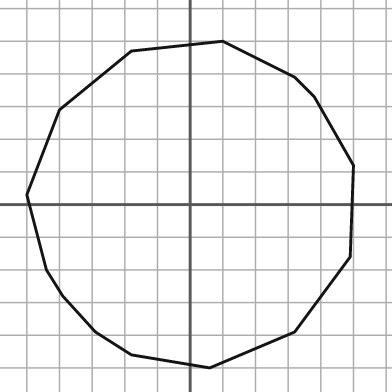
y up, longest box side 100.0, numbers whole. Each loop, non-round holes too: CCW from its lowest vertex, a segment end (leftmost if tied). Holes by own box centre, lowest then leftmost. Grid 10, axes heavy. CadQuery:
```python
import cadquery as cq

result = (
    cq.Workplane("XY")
    .moveTo(6.0, -50.0)
    .lineTo(32.0, -39.0)
    .lineTo(49.0, -16.0)
    .lineTo(50.0, 12.0)
    .lineTo(38.0, 33.0)
    .lineTo(32.0, 39.0)
    .lineTo(10.0, 50.0)
    .lineTo(-18.0, 47.0)
    .lineTo(-40.0, 29.0)
    .lineTo(-50.0, 3.0)
    .lineTo(-44.0, -20.0)
    .lineTo(-39.0, -28.0)
    .lineTo(-29.0, -39.0)
    .lineTo(-18.0, -46.0)
    .close()
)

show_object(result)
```